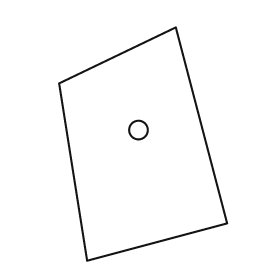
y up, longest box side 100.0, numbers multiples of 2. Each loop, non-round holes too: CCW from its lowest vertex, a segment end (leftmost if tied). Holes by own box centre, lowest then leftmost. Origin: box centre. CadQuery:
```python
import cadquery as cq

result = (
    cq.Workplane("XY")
    .moveTo(-24.0, -50.0)
    .lineTo(36.0, -34.0)
    .lineTo(14.0, 50.0)
    .lineTo(-36.0, 26.0)
    .close()
    .moveTo(-2.0, 6.0)
    .circle(4.0)
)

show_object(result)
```